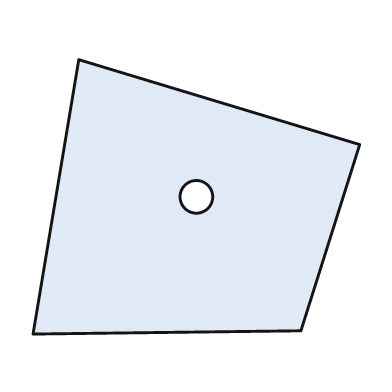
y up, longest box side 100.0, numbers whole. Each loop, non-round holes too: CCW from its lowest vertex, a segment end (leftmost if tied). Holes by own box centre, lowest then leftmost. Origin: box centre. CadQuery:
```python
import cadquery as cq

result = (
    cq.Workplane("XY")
    .moveTo(-50.0, -42.0)
    .lineTo(32.0, -41.0)
    .lineTo(50.0, 16.0)
    .lineTo(-36.0, 42.0)
    .close()
    .moveTo(0.0, 0.0)
    .circle(5.0)
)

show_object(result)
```